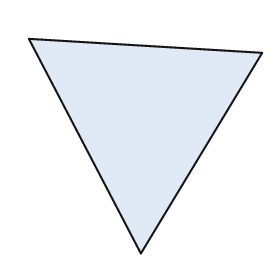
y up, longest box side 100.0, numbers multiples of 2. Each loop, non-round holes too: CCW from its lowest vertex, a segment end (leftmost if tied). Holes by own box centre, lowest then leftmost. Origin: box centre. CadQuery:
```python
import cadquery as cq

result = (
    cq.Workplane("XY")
    .moveTo(-2.0, -46.0)
    .lineTo(50.0, 40.0)
    .lineTo(-50.0, 46.0)
    .close()
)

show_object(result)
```